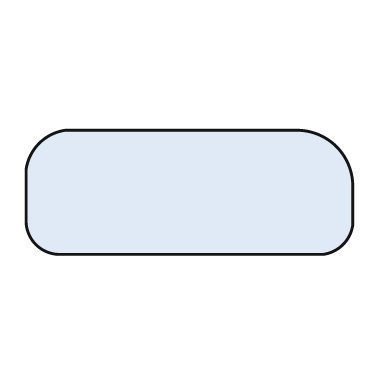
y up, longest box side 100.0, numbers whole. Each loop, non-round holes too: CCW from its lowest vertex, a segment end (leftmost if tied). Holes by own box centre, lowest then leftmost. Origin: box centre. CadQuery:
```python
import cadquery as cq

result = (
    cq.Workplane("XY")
    .moveTo(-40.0, -19.0)
    .lineTo(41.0, -19.0)
    .threePointArc((47.0, -16.0), (50.0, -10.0))
    .lineTo(50.0, 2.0)
    .threePointArc((45.0, 14.0), (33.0, 19.0))
    .lineTo(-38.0, 19.0)
    .threePointArc((-46.0, 15.0), (-50.0, 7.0))
    .lineTo(-50.0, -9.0)
    .threePointArc((-47.0, -16.0), (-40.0, -19.0))
    .close()
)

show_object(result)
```